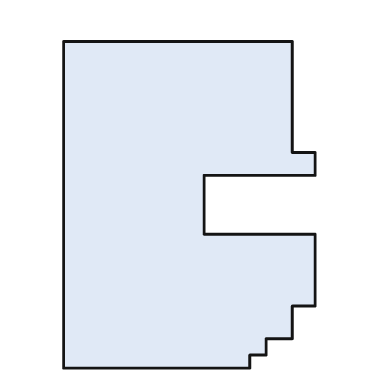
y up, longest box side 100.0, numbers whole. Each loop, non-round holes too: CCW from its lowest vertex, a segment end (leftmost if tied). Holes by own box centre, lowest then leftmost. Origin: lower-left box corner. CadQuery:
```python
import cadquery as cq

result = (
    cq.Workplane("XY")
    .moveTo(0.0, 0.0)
    .lineTo(57.0, 0.0)
    .lineTo(57.0, 4.0)
    .lineTo(62.0, 4.0)
    .lineTo(62.0, 9.0)
    .lineTo(70.0, 9.0)
    .lineTo(70.0, 19.0)
    .lineTo(77.0, 19.0)
    .lineTo(77.0, 41.0)
    .lineTo(43.0, 41.0)
    .lineTo(43.0, 59.0)
    .lineTo(77.0, 59.0)
    .lineTo(77.0, 66.0)
    .lineTo(70.0, 66.0)
    .lineTo(70.0, 100.0)
    .lineTo(0.0, 100.0)
    .close()
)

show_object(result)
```